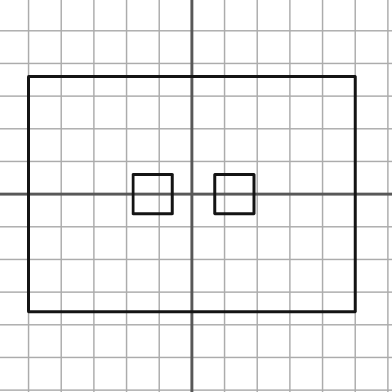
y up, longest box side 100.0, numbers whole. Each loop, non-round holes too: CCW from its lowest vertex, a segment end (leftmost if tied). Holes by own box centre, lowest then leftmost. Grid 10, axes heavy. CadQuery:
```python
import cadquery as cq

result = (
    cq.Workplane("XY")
    .moveTo(-50.0, -36.0)
    .lineTo(50.0, -36.0)
    .lineTo(50.0, 36.0)
    .lineTo(-50.0, 36.0)
    .close()
    .moveTo(-18.0, -6.0)
    .lineTo(-6.0, -6.0)
    .lineTo(-6.0, 6.0)
    .lineTo(-18.0, 6.0)
    .close()
    .moveTo(7.0, -6.0)
    .lineTo(19.0, -6.0)
    .lineTo(19.0, 6.0)
    .lineTo(7.0, 6.0)
    .close()
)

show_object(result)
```